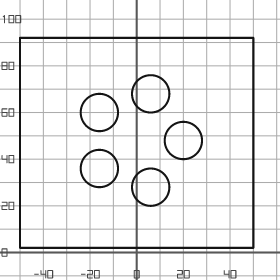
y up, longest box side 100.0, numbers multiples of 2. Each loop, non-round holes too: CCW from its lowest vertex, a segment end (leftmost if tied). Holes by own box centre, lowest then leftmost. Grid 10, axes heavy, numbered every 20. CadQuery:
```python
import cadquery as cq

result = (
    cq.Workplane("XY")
    .moveTo(-50.0, 2.0)
    .lineTo(50.0, 2.0)
    .lineTo(50.0, 92.0)
    .lineTo(-50.0, 92.0)
    .close()
    .moveTo(6.0, 28.0)
    .circle(8.0)
    .moveTo(-16.0, 36.0)
    .circle(8.0)
    .moveTo(20.0, 48.0)
    .circle(8.0)
    .moveTo(-16.0, 60.0)
    .circle(8.0)
    .moveTo(6.0, 68.0)
    .circle(8.0)
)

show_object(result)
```